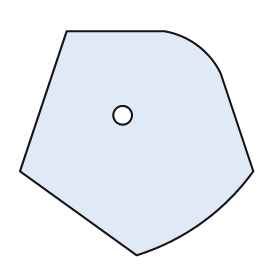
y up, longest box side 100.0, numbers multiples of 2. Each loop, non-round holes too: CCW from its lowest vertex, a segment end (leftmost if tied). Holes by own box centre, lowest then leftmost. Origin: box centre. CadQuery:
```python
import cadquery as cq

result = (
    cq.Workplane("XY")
    .moveTo(0.0, -48.0)
    .threePointArc((28.0, -34.0), (50.0, -12.0))
    .lineTo(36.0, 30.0)
    .threePointArc((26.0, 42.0), (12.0, 48.0))
    .lineTo(-30.0, 48.0)
    .lineTo(-50.0, -12.0)
    .close()
    .moveTo(-6.0, 12.0)
    .circle(4.0)
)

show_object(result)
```